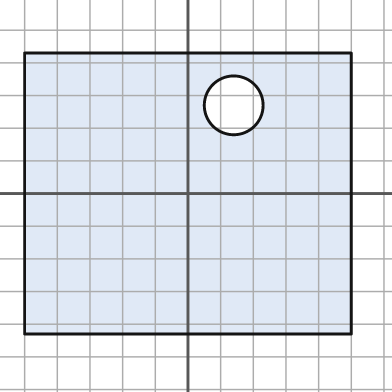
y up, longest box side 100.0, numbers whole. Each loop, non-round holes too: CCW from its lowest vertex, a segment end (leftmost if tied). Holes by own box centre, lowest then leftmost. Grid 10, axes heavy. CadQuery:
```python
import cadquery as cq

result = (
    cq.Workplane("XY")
    .moveTo(-50.0, -43.0)
    .lineTo(50.0, -43.0)
    .lineTo(50.0, 43.0)
    .lineTo(-50.0, 43.0)
    .close()
    .moveTo(14.0, 27.0)
    .circle(9.0)
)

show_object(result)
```